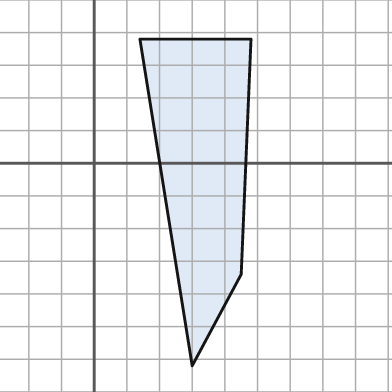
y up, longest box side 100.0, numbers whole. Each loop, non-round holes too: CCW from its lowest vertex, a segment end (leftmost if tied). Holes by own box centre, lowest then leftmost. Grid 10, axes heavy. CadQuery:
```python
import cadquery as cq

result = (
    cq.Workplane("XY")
    .moveTo(30.0, -62.0)
    .lineTo(45.0, -34.0)
    .lineTo(48.0, 38.0)
    .lineTo(14.0, 38.0)
    .close()
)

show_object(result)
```